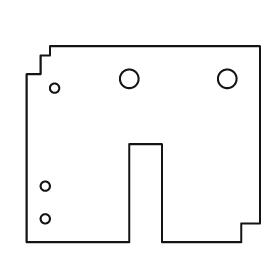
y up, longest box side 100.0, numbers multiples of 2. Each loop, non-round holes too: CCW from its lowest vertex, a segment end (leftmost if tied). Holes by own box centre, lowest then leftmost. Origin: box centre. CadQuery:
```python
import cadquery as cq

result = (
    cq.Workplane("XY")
    .moveTo(-50.0, -42.0)
    .lineTo(-6.0, -42.0)
    .lineTo(-6.0, 0.0)
    .lineTo(8.0, 0.0)
    .lineTo(8.0, -42.0)
    .lineTo(42.0, -42.0)
    .lineTo(42.0, -34.0)
    .lineTo(50.0, -34.0)
    .lineTo(50.0, 42.0)
    .lineTo(-40.0, 42.0)
    .lineTo(-40.0, 38.0)
    .lineTo(-44.0, 38.0)
    .lineTo(-44.0, 30.0)
    .lineTo(-50.0, 30.0)
    .close()
    .moveTo(-42.0, -32.0)
    .circle(2.0)
    .moveTo(-42.0, -18.0)
    .circle(2.0)
    .moveTo(-38.0, 24.0)
    .circle(2.0)
    .moveTo(-6.0, 28.0)
    .circle(4.0)
    .moveTo(36.0, 28.0)
    .circle(4.0)
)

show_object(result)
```